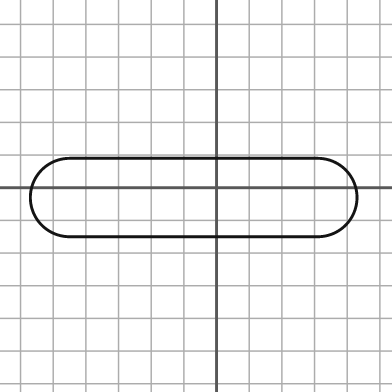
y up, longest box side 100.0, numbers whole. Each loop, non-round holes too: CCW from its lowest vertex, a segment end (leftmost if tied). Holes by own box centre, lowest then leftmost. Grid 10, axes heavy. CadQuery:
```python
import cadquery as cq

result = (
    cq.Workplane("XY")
    .moveTo(-45.0, -15.0)
    .lineTo(31.0, -15.0)
    .threePointArc((43.0, -3.0), (31.0, 9.0))
    .lineTo(-45.0, 9.0)
    .threePointArc((-57.0, -3.0), (-45.0, -15.0))
    .close()
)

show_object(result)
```